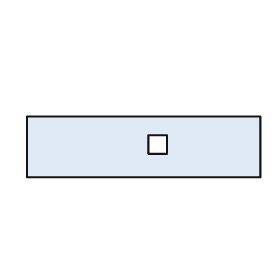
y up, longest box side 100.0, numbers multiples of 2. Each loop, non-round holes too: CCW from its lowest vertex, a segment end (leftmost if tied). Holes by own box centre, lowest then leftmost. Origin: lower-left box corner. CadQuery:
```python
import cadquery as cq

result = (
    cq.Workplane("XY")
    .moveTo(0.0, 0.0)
    .lineTo(100.0, 0.0)
    .lineTo(100.0, 26.0)
    .lineTo(0.0, 26.0)
    .close()
    .moveTo(52.0, 10.0)
    .lineTo(60.0, 10.0)
    .lineTo(60.0, 18.0)
    .lineTo(52.0, 18.0)
    .close()
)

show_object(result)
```